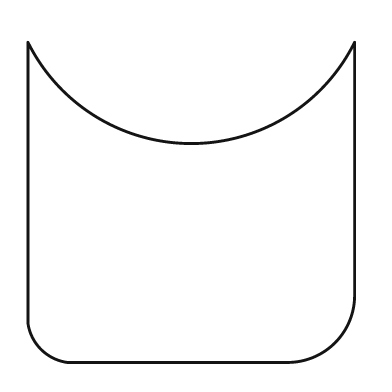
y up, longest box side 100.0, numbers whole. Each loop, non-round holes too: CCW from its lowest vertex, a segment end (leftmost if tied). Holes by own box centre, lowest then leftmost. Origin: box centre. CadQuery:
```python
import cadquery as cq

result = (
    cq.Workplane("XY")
    .moveTo(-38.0, -49.0)
    .lineTo(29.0, -49.0)
    .threePointArc((44.0, -43.0), (50.0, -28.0))
    .lineTo(50.0, 49.0)
    .threePointArc((0.0, 18.0), (-50.0, 49.0))
    .lineTo(-50.0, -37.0)
    .threePointArc((-46.0, -45.0), (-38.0, -49.0))
    .close()
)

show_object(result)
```